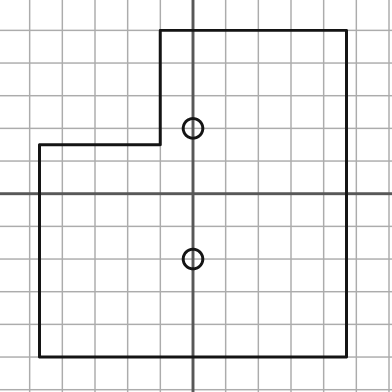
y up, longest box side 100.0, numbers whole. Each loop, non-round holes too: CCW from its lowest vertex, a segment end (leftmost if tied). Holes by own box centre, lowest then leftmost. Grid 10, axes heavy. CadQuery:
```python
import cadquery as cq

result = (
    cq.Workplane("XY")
    .moveTo(-47.0, -50.0)
    .lineTo(47.0, -50.0)
    .lineTo(47.0, 50.0)
    .lineTo(-10.0, 50.0)
    .lineTo(-10.0, 15.0)
    .lineTo(-47.0, 15.0)
    .close()
    .moveTo(0.0, -20.0)
    .circle(3.0)
    .moveTo(0.0, 20.0)
    .circle(3.0)
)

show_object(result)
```